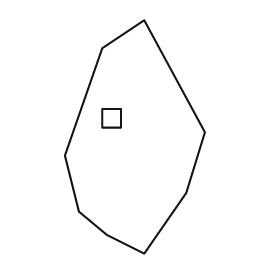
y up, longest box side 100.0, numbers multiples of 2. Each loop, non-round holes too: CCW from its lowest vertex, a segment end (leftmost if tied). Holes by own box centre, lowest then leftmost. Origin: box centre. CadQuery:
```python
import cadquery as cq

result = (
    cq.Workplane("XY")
    .moveTo(4.0, -50.0)
    .lineTo(22.0, -24.0)
    .lineTo(30.0, 2.0)
    .lineTo(4.0, 50.0)
    .lineTo(-14.0, 38.0)
    .lineTo(-30.0, -8.0)
    .lineTo(-24.0, -32.0)
    .lineTo(-12.0, -42.0)
    .close()
    .moveTo(-14.0, 4.0)
    .lineTo(-6.0, 4.0)
    .lineTo(-6.0, 12.0)
    .lineTo(-14.0, 12.0)
    .close()
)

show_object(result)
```